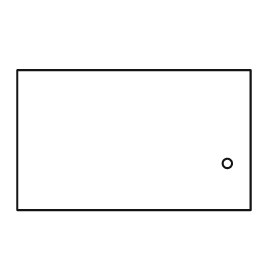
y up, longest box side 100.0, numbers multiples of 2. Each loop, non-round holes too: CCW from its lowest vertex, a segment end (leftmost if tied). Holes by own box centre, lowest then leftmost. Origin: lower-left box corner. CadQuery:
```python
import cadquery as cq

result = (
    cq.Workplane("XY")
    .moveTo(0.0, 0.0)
    .lineTo(100.0, 0.0)
    .lineTo(100.0, 60.0)
    .lineTo(0.0, 60.0)
    .close()
    .moveTo(90.0, 20.0)
    .circle(2.0)
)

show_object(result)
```